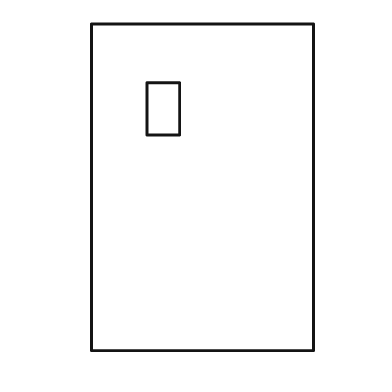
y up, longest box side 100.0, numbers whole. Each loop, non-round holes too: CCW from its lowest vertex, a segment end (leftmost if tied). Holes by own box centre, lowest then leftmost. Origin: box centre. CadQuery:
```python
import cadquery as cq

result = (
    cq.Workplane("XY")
    .moveTo(-34.0, -50.0)
    .lineTo(34.0, -50.0)
    .lineTo(34.0, 50.0)
    .lineTo(-34.0, 50.0)
    .close()
    .moveTo(-17.0, 16.0)
    .lineTo(-7.0, 16.0)
    .lineTo(-7.0, 32.0)
    .lineTo(-17.0, 32.0)
    .close()
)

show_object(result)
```